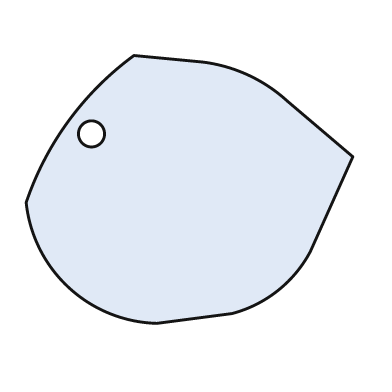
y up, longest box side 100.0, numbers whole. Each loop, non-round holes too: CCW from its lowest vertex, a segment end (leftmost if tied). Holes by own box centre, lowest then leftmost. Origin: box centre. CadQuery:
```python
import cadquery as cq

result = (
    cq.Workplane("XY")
    .moveTo(-10.0, -41.0)
    .lineTo(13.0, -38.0)
    .threePointArc((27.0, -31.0), (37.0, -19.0))
    .lineTo(50.0, 10.0)
    .lineTo(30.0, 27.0)
    .threePointArc((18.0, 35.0), (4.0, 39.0))
    .lineTo(-17.0, 41.0)
    .threePointArc((-37.0, 21.0), (-50.0, -4.0))
    .threePointArc((-37.0, -30.0), (-10.0, -41.0))
    .close()
    .moveTo(-30.0, 17.0)
    .circle(4.0)
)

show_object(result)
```